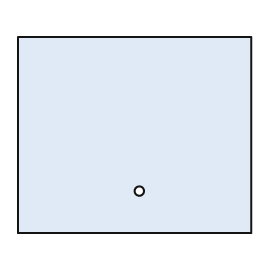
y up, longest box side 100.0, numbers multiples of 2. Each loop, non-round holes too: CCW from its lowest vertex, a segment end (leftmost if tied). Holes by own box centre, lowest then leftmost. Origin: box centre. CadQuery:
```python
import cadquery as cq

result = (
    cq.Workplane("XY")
    .moveTo(-50.0, -42.0)
    .lineTo(50.0, -42.0)
    .lineTo(50.0, 42.0)
    .lineTo(-50.0, 42.0)
    .close()
    .moveTo(2.0, -24.0)
    .circle(2.0)
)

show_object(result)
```